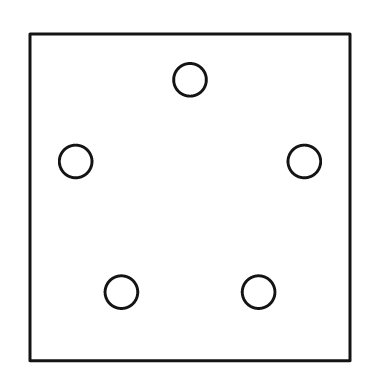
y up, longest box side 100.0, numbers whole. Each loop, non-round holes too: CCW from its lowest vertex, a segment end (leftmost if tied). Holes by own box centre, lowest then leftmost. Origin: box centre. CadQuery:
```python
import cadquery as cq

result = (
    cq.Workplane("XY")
    .moveTo(-49.0, -50.0)
    .lineTo(49.0, -50.0)
    .lineTo(49.0, 50.0)
    .lineTo(-49.0, 50.0)
    .close()
    .moveTo(-21.0, -29.0)
    .circle(5.0)
    .moveTo(21.0, -29.0)
    .circle(5.0)
    .moveTo(-35.0, 11.0)
    .circle(5.0)
    .moveTo(35.0, 11.0)
    .circle(5.0)
    .moveTo(0.0, 36.0)
    .circle(5.0)
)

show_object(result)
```